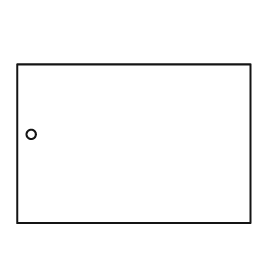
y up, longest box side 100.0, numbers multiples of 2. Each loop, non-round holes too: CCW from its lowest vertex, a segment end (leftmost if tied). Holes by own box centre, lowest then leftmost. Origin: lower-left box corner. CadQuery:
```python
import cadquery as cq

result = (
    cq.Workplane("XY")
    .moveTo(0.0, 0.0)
    .lineTo(100.0, 0.0)
    .lineTo(100.0, 68.0)
    .lineTo(0.0, 68.0)
    .close()
    .moveTo(6.0, 38.0)
    .circle(2.0)
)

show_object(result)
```